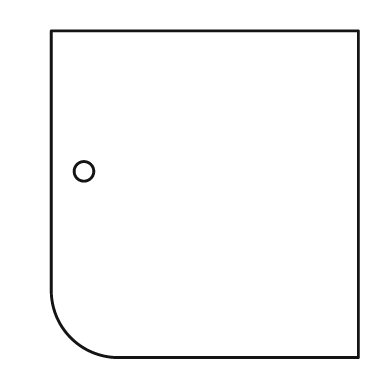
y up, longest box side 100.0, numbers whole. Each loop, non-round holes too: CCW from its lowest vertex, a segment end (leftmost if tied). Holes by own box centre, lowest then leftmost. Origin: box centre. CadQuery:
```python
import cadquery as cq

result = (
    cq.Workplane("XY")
    .moveTo(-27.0, -50.0)
    .lineTo(47.0, -50.0)
    .lineTo(47.0, 50.0)
    .lineTo(-47.0, 50.0)
    .lineTo(-47.0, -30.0)
    .threePointArc((-41.0, -44.0), (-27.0, -50.0))
    .close()
    .moveTo(-37.0, 7.0)
    .circle(3.0)
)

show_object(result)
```